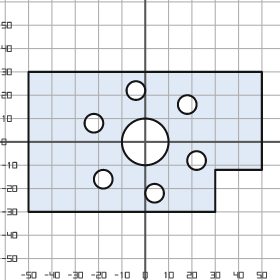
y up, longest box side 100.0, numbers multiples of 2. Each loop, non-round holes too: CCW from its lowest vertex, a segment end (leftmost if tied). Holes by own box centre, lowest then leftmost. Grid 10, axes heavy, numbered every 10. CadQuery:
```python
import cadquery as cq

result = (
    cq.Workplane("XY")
    .moveTo(-50.0, -30.0)
    .lineTo(30.0, -30.0)
    .lineTo(30.0, -12.0)
    .lineTo(50.0, -12.0)
    .lineTo(50.0, 30.0)
    .lineTo(-50.0, 30.0)
    .close()
    .moveTo(4.0, -22.0)
    .circle(4.0)
    .moveTo(-18.0, -16.0)
    .circle(4.0)
    .moveTo(22.0, -8.0)
    .circle(4.0)
    .moveTo(0.0, 0.0)
    .circle(10.0)
    .moveTo(-22.0, 8.0)
    .circle(4.0)
    .moveTo(18.0, 16.0)
    .circle(4.0)
    .moveTo(-4.0, 22.0)
    .circle(4.0)
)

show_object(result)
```